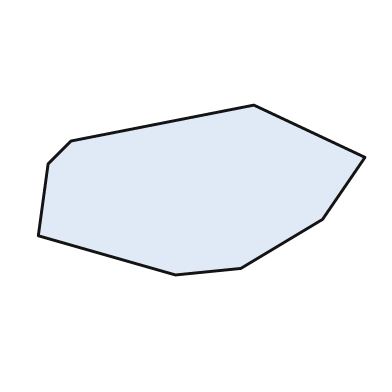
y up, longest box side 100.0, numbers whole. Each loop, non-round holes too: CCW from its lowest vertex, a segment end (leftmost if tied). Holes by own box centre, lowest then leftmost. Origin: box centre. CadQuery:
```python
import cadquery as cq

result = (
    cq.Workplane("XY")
    .moveTo(-8.0, -26.0)
    .lineTo(12.0, -24.0)
    .lineTo(37.0, -9.0)
    .lineTo(50.0, 10.0)
    .lineTo(16.0, 26.0)
    .lineTo(-40.0, 15.0)
    .lineTo(-47.0, 8.0)
    .lineTo(-50.0, -14.0)
    .close()
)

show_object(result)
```